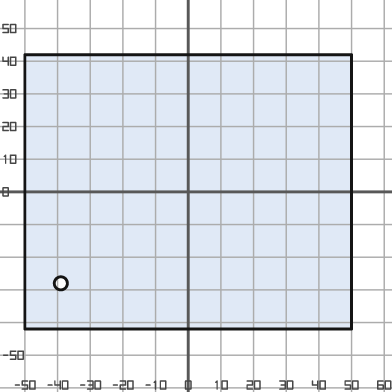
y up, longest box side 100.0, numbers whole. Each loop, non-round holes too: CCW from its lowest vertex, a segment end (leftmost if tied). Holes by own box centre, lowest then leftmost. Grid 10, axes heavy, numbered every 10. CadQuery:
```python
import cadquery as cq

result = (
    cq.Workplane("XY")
    .moveTo(-50.0, -42.0)
    .lineTo(50.0, -42.0)
    .lineTo(50.0, 42.0)
    .lineTo(-50.0, 42.0)
    .close()
    .moveTo(-39.0, -28.0)
    .circle(2.0)
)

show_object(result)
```